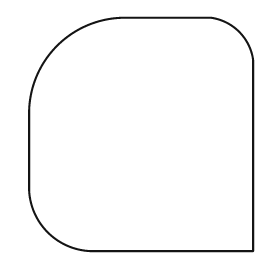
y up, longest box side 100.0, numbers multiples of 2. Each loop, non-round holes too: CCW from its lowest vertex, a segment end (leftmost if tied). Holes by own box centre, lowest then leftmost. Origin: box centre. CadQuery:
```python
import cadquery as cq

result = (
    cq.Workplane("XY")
    .moveTo(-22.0, -50.0)
    .lineTo(48.0, -50.0)
    .lineTo(48.0, 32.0)
    .threePointArc((42.0, 44.0), (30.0, 50.0))
    .lineTo(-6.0, 50.0)
    .threePointArc((-36.0, 38.0), (-48.0, 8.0))
    .lineTo(-48.0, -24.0)
    .threePointArc((-40.0, -42.0), (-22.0, -50.0))
    .close()
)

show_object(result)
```